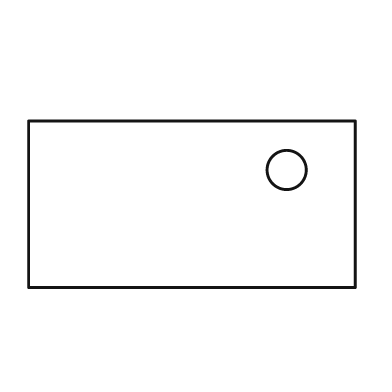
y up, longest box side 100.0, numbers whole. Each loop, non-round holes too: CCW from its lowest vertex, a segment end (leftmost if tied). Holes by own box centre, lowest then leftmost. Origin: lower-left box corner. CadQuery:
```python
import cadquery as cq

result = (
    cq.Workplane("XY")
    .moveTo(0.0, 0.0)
    .lineTo(100.0, 0.0)
    .lineTo(100.0, 51.0)
    .lineTo(0.0, 51.0)
    .close()
    .moveTo(79.0, 36.0)
    .circle(6.0)
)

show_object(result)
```